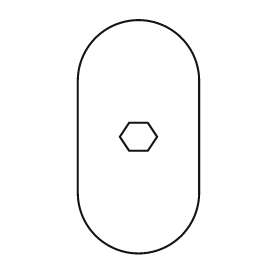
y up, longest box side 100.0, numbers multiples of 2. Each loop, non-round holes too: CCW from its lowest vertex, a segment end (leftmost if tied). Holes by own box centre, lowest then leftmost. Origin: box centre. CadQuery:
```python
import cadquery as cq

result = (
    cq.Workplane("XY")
    .moveTo(-26.0, -24.0)
    .threePointArc((0.0, -50.0), (26.0, -24.0))
    .lineTo(26.0, 24.0)
    .threePointArc((0.0, 50.0), (-26.0, 24.0))
    .close()
    .moveTo(-4.0, -6.0)
    .lineTo(4.0, -6.0)
    .lineTo(8.0, 0.0)
    .lineTo(4.0, 6.0)
    .lineTo(-4.0, 6.0)
    .lineTo(-8.0, 0.0)
    .close()
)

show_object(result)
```